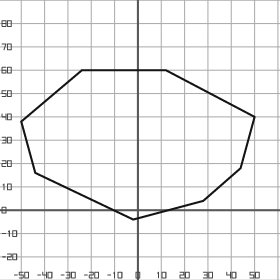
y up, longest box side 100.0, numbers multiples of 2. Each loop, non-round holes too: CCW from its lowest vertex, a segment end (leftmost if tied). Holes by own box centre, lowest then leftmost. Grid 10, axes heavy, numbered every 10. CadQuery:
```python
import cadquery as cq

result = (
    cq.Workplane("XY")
    .moveTo(-2.0, -4.0)
    .lineTo(28.0, 4.0)
    .lineTo(44.0, 18.0)
    .lineTo(50.0, 40.0)
    .lineTo(12.0, 60.0)
    .lineTo(-24.0, 60.0)
    .lineTo(-50.0, 38.0)
    .lineTo(-44.0, 16.0)
    .close()
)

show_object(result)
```